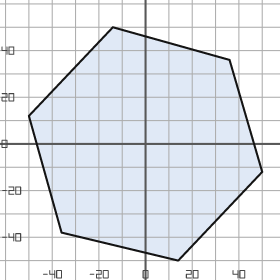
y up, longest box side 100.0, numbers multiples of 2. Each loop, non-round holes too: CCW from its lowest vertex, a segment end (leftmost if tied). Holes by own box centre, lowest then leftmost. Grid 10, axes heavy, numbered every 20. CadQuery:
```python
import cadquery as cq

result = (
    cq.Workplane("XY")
    .moveTo(14.0, -50.0)
    .lineTo(50.0, -12.0)
    .lineTo(36.0, 36.0)
    .lineTo(-14.0, 50.0)
    .lineTo(-50.0, 12.0)
    .lineTo(-36.0, -38.0)
    .close()
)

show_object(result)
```